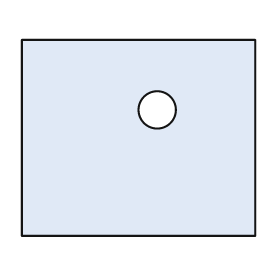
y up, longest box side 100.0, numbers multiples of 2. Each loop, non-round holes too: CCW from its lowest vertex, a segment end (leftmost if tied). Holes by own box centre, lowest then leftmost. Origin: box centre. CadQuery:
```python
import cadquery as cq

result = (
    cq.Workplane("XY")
    .moveTo(-50.0, -42.0)
    .lineTo(50.0, -42.0)
    .lineTo(50.0, 42.0)
    .lineTo(-50.0, 42.0)
    .close()
    .moveTo(8.0, 12.0)
    .circle(8.0)
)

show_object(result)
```